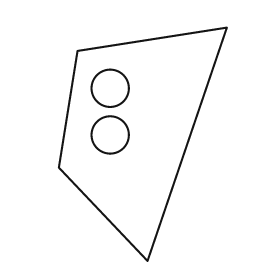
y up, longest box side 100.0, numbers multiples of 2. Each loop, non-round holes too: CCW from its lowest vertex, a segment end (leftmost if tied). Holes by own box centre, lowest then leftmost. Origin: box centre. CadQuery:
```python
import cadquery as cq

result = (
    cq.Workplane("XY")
    .moveTo(2.0, -50.0)
    .lineTo(36.0, 50.0)
    .lineTo(-28.0, 40.0)
    .lineTo(-36.0, -10.0)
    .close()
    .moveTo(-14.0, 4.0)
    .circle(8.0)
    .moveTo(-14.0, 24.0)
    .circle(8.0)
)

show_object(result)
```